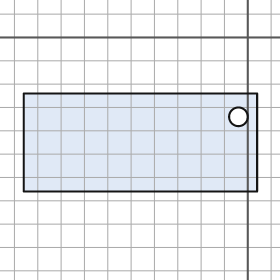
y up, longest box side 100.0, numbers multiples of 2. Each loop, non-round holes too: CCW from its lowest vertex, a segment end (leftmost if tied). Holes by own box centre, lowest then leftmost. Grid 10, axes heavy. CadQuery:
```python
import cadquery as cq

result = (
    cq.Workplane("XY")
    .moveTo(-96.0, -66.0)
    .lineTo(4.0, -66.0)
    .lineTo(4.0, -24.0)
    .lineTo(-96.0, -24.0)
    .close()
    .moveTo(-4.0, -34.0)
    .circle(4.0)
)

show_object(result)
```